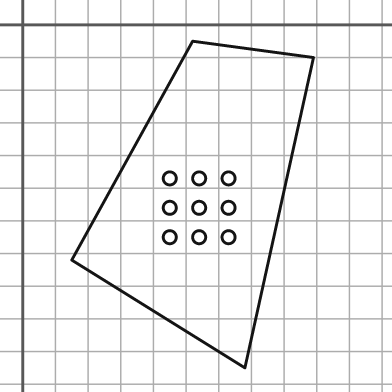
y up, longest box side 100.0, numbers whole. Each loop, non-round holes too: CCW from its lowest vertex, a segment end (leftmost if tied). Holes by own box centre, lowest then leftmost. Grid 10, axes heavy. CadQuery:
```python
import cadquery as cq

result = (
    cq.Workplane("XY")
    .moveTo(68.0, -105.0)
    .lineTo(89.0, -10.0)
    .lineTo(52.0, -5.0)
    .lineTo(15.0, -72.0)
    .close()
    .moveTo(45.0, -65.0)
    .circle(2.0)
    .moveTo(54.0, -65.0)
    .circle(2.0)
    .moveTo(63.0, -65.0)
    .circle(2.0)
    .moveTo(45.0, -56.0)
    .circle(2.0)
    .moveTo(54.0, -56.0)
    .circle(2.0)
    .moveTo(63.0, -56.0)
    .circle(2.0)
    .moveTo(45.0, -47.0)
    .circle(2.0)
    .moveTo(54.0, -47.0)
    .circle(2.0)
    .moveTo(63.0, -47.0)
    .circle(2.0)
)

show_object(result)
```